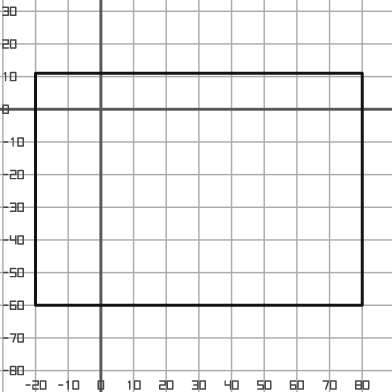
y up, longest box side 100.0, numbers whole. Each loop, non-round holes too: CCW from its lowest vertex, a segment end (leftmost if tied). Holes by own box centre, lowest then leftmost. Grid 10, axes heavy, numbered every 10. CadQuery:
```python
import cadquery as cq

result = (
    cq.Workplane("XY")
    .moveTo(-20.0, -60.0)
    .lineTo(80.0, -60.0)
    .lineTo(80.0, 11.0)
    .lineTo(-20.0, 11.0)
    .close()
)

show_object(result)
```